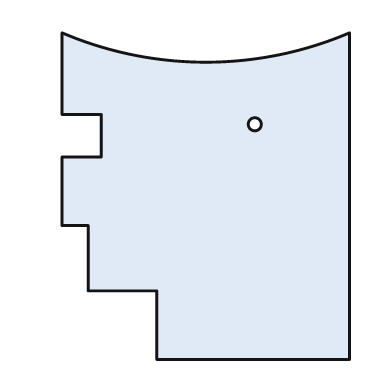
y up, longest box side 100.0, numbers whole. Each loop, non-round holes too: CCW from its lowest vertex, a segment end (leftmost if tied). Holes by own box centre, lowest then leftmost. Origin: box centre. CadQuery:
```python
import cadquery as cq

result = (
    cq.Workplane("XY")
    .moveTo(-15.0, -50.0)
    .lineTo(44.0, -50.0)
    .lineTo(44.0, 50.0)
    .threePointArc((0.0, 41.0), (-44.0, 50.0))
    .lineTo(-44.0, 25.0)
    .lineTo(-32.0, 25.0)
    .lineTo(-32.0, 12.0)
    .lineTo(-44.0, 12.0)
    .lineTo(-44.0, -9.0)
    .lineTo(-36.0, -9.0)
    .lineTo(-36.0, -29.0)
    .lineTo(-15.0, -29.0)
    .close()
    .moveTo(15.0, 22.0)
    .circle(2.0)
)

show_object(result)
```